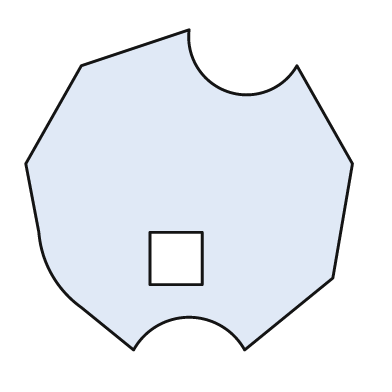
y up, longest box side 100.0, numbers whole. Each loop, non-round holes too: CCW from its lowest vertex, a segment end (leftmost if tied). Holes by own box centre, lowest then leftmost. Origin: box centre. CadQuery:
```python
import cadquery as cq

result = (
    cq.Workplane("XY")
    .moveTo(-17.0, -49.0)
    .threePointArc((0.0, -39.0), (17.0, -49.0))
    .lineTo(44.0, -27.0)
    .lineTo(50.0, 8.0)
    .lineTo(33.0, 38.0)
    .threePointArc((12.0, 30.0), (0.0, 49.0))
    .lineTo(-33.0, 38.0)
    .lineTo(-50.0, 8.0)
    .lineTo(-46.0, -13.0)
    .threePointArc((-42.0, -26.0), (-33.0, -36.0))
    .close()
    .moveTo(-12.0, -29.0)
    .lineTo(4.0, -29.0)
    .lineTo(4.0, -13.0)
    .lineTo(-12.0, -13.0)
    .close()
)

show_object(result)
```